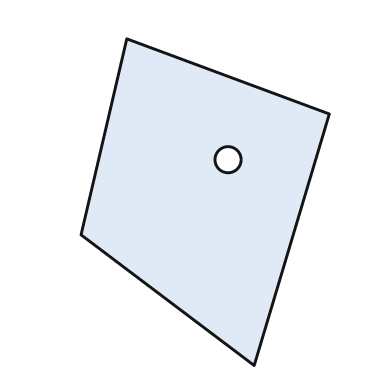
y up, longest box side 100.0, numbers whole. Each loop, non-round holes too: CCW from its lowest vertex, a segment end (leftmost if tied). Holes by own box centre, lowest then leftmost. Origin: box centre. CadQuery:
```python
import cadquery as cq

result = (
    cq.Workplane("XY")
    .moveTo(15.0, -50.0)
    .lineTo(38.0, 27.0)
    .lineTo(-24.0, 50.0)
    .lineTo(-38.0, -10.0)
    .close()
    .moveTo(7.0, 13.0)
    .circle(4.0)
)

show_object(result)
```